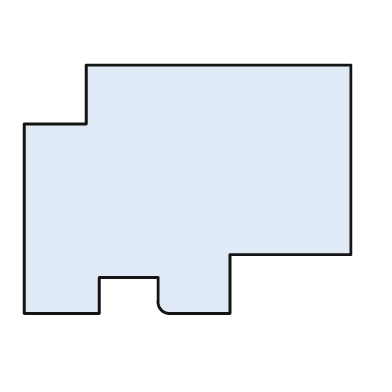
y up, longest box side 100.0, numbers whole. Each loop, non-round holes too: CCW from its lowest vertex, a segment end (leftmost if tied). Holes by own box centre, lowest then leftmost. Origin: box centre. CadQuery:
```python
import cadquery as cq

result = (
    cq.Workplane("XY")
    .moveTo(-50.0, -38.0)
    .lineTo(-27.0, -38.0)
    .lineTo(-27.0, -27.0)
    .lineTo(-9.0, -27.0)
    .lineTo(-9.0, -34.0)
    .threePointArc((-8.0, -37.0), (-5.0, -38.0))
    .lineTo(13.0, -38.0)
    .lineTo(13.0, -20.0)
    .lineTo(50.0, -20.0)
    .lineTo(50.0, 38.0)
    .lineTo(-31.0, 38.0)
    .lineTo(-31.0, 20.0)
    .lineTo(-50.0, 20.0)
    .close()
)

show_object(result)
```